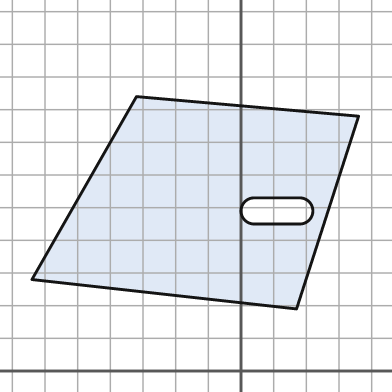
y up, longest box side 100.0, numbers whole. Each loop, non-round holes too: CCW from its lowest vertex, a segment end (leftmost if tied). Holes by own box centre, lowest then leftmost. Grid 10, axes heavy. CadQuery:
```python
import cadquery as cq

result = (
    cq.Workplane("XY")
    .moveTo(17.0, 19.0)
    .lineTo(36.0, 78.0)
    .lineTo(-32.0, 84.0)
    .lineTo(-64.0, 28.0)
    .close()
    .moveTo(4.0, 45.0)
    .lineTo(18.0, 45.0)
    .threePointArc((22.0, 49.0), (18.0, 53.0))
    .lineTo(4.0, 53.0)
    .threePointArc((0.0, 49.0), (4.0, 45.0))
    .close()
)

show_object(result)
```